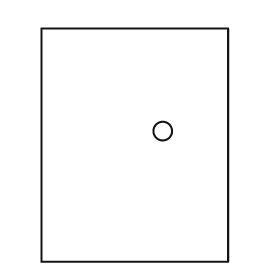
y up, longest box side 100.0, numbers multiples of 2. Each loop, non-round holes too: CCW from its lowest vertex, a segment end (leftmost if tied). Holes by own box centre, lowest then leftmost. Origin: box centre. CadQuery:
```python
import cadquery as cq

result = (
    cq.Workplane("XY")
    .moveTo(-40.0, -50.0)
    .lineTo(40.0, -50.0)
    .lineTo(40.0, 50.0)
    .lineTo(-40.0, 50.0)
    .close()
    .moveTo(12.0, 6.0)
    .circle(4.0)
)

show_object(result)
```